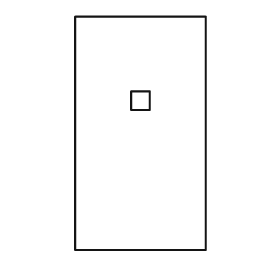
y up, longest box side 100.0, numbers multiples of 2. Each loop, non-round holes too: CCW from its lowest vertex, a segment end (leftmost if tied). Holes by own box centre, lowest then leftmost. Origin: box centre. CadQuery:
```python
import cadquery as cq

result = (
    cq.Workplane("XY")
    .moveTo(-28.0, -50.0)
    .lineTo(28.0, -50.0)
    .lineTo(28.0, 50.0)
    .lineTo(-28.0, 50.0)
    .close()
    .moveTo(-4.0, 10.0)
    .lineTo(4.0, 10.0)
    .lineTo(4.0, 18.0)
    .lineTo(-4.0, 18.0)
    .close()
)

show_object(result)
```